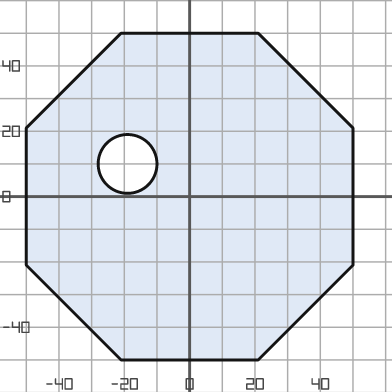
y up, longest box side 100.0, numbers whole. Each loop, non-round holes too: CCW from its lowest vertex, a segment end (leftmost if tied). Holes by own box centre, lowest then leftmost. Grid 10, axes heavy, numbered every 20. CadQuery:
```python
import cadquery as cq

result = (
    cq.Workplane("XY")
    .moveTo(-21.0, -50.0)
    .lineTo(21.0, -50.0)
    .lineTo(50.0, -21.0)
    .lineTo(50.0, 21.0)
    .lineTo(21.0, 50.0)
    .lineTo(-21.0, 50.0)
    .lineTo(-50.0, 21.0)
    .lineTo(-50.0, -21.0)
    .close()
    .moveTo(-19.0, 10.0)
    .circle(9.0)
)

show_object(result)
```